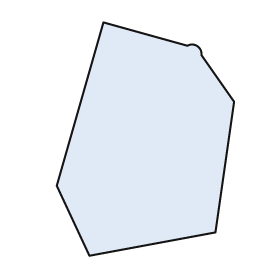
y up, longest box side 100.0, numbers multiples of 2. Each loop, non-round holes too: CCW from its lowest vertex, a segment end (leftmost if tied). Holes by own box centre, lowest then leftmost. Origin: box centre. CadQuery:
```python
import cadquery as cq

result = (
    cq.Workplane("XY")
    .moveTo(-24.0, -50.0)
    .lineTo(30.0, -40.0)
    .lineTo(38.0, 16.0)
    .lineTo(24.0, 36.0)
    .threePointArc((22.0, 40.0), (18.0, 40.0))
    .lineTo(-18.0, 50.0)
    .lineTo(-38.0, -20.0)
    .close()
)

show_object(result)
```